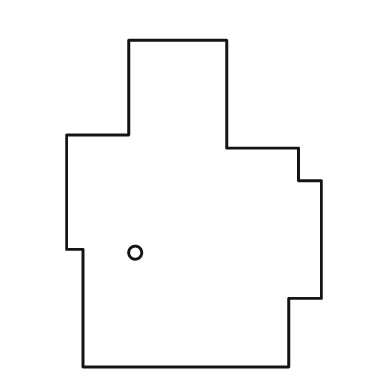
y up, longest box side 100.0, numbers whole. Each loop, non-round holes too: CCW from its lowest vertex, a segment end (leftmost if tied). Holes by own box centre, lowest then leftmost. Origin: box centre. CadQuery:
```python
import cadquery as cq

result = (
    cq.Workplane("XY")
    .moveTo(-34.0, -50.0)
    .lineTo(29.0, -50.0)
    .lineTo(29.0, -29.0)
    .lineTo(39.0, -29.0)
    .lineTo(39.0, 7.0)
    .lineTo(32.0, 7.0)
    .lineTo(32.0, 17.0)
    .lineTo(10.0, 17.0)
    .lineTo(10.0, 50.0)
    .lineTo(-20.0, 50.0)
    .lineTo(-20.0, 21.0)
    .lineTo(-39.0, 21.0)
    .lineTo(-39.0, -14.0)
    .lineTo(-34.0, -14.0)
    .close()
    .moveTo(-18.0, -15.0)
    .circle(2.0)
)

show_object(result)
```